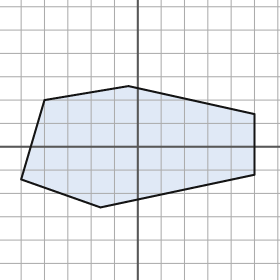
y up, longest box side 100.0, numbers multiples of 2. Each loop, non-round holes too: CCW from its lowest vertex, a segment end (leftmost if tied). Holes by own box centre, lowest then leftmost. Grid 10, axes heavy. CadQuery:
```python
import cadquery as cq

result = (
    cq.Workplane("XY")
    .moveTo(-16.0, -26.0)
    .lineTo(50.0, -12.0)
    .lineTo(50.0, 14.0)
    .lineTo(-4.0, 26.0)
    .lineTo(-40.0, 20.0)
    .lineTo(-50.0, -14.0)
    .close()
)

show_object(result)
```